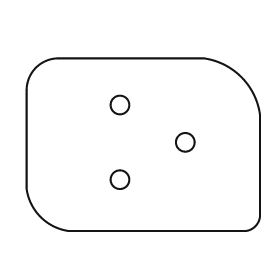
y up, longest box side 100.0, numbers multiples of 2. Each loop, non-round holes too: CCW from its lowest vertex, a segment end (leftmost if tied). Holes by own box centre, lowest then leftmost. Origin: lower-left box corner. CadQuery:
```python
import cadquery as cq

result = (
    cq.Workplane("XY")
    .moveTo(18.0, 0.0)
    .lineTo(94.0, 0.0)
    .threePointArc((98.0, 2.0), (100.0, 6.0))
    .lineTo(100.0, 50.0)
    .threePointArc((92.0, 66.0), (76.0, 74.0))
    .lineTo(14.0, 74.0)
    .threePointArc((4.0, 70.0), (0.0, 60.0))
    .lineTo(0.0, 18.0)
    .threePointArc((6.0, 6.0), (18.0, 0.0))
    .close()
    .moveTo(40.0, 22.0)
    .circle(4.0)
    .moveTo(68.0, 38.0)
    .circle(4.0)
    .moveTo(40.0, 54.0)
    .circle(4.0)
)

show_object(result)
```